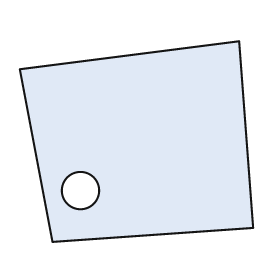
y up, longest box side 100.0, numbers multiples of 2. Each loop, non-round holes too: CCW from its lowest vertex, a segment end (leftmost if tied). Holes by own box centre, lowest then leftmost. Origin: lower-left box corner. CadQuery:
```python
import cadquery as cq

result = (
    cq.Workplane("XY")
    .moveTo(14.0, 0.0)
    .lineTo(100.0, 6.0)
    .lineTo(94.0, 86.0)
    .lineTo(0.0, 74.0)
    .close()
    .moveTo(26.0, 22.0)
    .circle(8.0)
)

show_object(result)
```